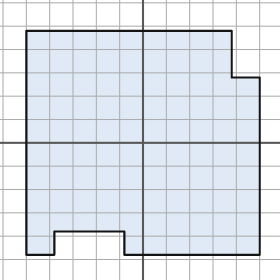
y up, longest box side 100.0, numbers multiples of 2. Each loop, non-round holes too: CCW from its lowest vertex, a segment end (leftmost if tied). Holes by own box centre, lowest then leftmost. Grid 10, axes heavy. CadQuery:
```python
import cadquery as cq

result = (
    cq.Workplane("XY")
    .moveTo(-50.0, -48.0)
    .lineTo(-38.0, -48.0)
    .lineTo(-38.0, -38.0)
    .lineTo(-8.0, -38.0)
    .lineTo(-8.0, -48.0)
    .lineTo(50.0, -48.0)
    .lineTo(50.0, 28.0)
    .lineTo(38.0, 28.0)
    .lineTo(38.0, 48.0)
    .lineTo(-50.0, 48.0)
    .close()
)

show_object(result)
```